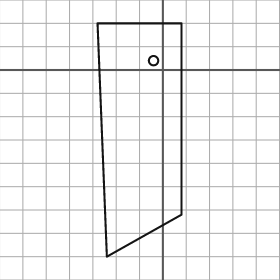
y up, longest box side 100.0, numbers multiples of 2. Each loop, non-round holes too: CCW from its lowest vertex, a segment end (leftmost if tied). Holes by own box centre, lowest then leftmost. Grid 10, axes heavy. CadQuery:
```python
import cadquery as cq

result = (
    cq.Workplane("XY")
    .moveTo(-24.0, -80.0)
    .lineTo(8.0, -62.0)
    .lineTo(8.0, 20.0)
    .lineTo(-28.0, 20.0)
    .close()
    .moveTo(-4.0, 4.0)
    .circle(2.0)
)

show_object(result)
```